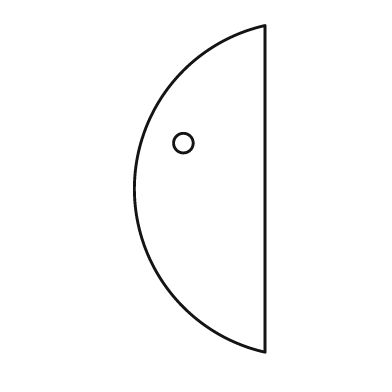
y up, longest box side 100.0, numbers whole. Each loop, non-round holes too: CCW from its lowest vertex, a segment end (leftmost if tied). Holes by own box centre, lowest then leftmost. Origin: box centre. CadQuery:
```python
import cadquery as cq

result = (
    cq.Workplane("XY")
    .moveTo(20.0, -50.0)
    .lineTo(20.0, 50.0)
    .threePointArc((-20.0, 0.0), (20.0, -50.0))
    .close()
    .moveTo(-5.0, 14.0)
    .circle(3.0)
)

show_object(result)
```